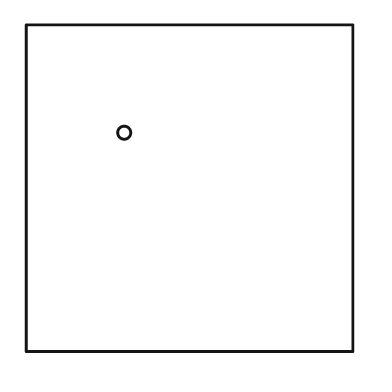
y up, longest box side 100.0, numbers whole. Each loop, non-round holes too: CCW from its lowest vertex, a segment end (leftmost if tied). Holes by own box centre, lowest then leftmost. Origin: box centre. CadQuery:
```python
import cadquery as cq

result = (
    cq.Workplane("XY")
    .moveTo(-50.0, -50.0)
    .lineTo(50.0, -50.0)
    .lineTo(50.0, 50.0)
    .lineTo(-50.0, 50.0)
    .close()
    .moveTo(-20.0, 17.0)
    .circle(2.0)
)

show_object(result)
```